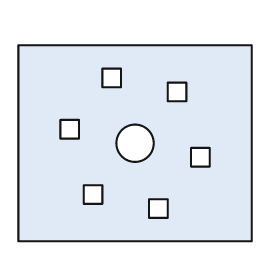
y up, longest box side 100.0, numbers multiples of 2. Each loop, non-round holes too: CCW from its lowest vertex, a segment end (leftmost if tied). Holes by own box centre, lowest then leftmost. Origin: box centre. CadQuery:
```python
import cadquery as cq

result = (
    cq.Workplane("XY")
    .moveTo(-50.0, -42.0)
    .lineTo(50.0, -42.0)
    .lineTo(50.0, 42.0)
    .lineTo(-50.0, 42.0)
    .close()
    .moveTo(6.0, -32.0)
    .lineTo(14.0, -32.0)
    .lineTo(14.0, -24.0)
    .lineTo(6.0, -24.0)
    .close()
    .moveTo(-22.0, -26.0)
    .lineTo(-14.0, -26.0)
    .lineTo(-14.0, -18.0)
    .lineTo(-22.0, -18.0)
    .close()
    .moveTo(24.0, -10.0)
    .lineTo(32.0, -10.0)
    .lineTo(32.0, -2.0)
    .lineTo(24.0, -2.0)
    .close()
    .moveTo(0.0, 0.0)
    .circle(8.0)
    .moveTo(-32.0, 2.0)
    .lineTo(-24.0, 2.0)
    .lineTo(-24.0, 10.0)
    .lineTo(-32.0, 10.0)
    .close()
    .moveTo(14.0, 18.0)
    .lineTo(22.0, 18.0)
    .lineTo(22.0, 26.0)
    .lineTo(14.0, 26.0)
    .close()
    .moveTo(-14.0, 24.0)
    .lineTo(-6.0, 24.0)
    .lineTo(-6.0, 32.0)
    .lineTo(-14.0, 32.0)
    .close()
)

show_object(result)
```